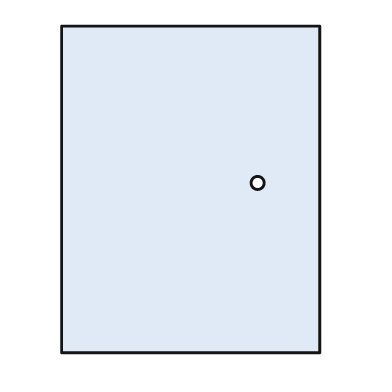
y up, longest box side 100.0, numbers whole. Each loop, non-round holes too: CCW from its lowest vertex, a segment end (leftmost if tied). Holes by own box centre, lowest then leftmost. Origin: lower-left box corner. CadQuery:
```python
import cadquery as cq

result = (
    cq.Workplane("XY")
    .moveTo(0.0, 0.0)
    .lineTo(79.0, 0.0)
    .lineTo(79.0, 100.0)
    .lineTo(0.0, 100.0)
    .close()
    .moveTo(60.0, 52.0)
    .circle(2.0)
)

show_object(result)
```